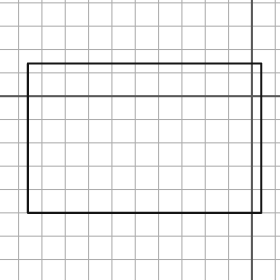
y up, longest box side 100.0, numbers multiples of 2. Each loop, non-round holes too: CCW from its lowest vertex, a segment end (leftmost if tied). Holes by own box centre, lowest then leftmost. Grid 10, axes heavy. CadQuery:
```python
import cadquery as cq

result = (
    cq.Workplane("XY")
    .moveTo(-96.0, -50.0)
    .lineTo(4.0, -50.0)
    .lineTo(4.0, 14.0)
    .lineTo(-96.0, 14.0)
    .close()
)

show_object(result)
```